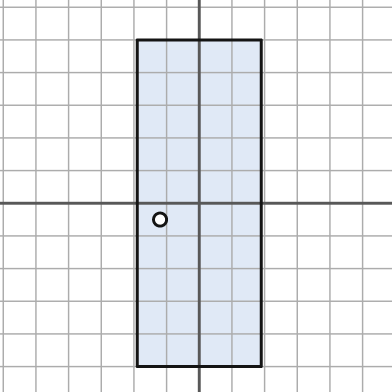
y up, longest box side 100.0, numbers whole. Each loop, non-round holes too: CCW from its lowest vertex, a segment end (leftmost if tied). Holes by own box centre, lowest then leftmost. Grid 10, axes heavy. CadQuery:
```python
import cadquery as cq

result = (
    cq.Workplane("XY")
    .moveTo(-19.0, -50.0)
    .lineTo(19.0, -50.0)
    .lineTo(19.0, 50.0)
    .lineTo(-19.0, 50.0)
    .close()
    .moveTo(-12.0, -5.0)
    .circle(2.0)
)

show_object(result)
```